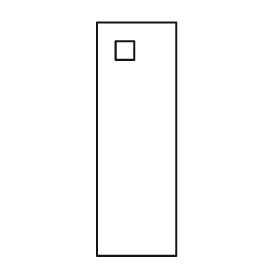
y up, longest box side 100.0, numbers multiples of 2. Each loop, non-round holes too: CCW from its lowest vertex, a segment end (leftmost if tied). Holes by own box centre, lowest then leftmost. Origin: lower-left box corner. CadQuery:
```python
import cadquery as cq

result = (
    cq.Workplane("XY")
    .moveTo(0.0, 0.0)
    .lineTo(34.0, 0.0)
    .lineTo(34.0, 100.0)
    .lineTo(0.0, 100.0)
    .close()
    .moveTo(8.0, 84.0)
    .lineTo(16.0, 84.0)
    .lineTo(16.0, 92.0)
    .lineTo(8.0, 92.0)
    .close()
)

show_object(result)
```